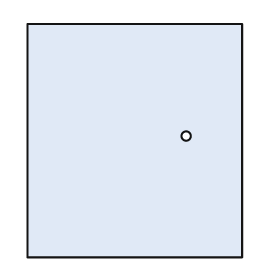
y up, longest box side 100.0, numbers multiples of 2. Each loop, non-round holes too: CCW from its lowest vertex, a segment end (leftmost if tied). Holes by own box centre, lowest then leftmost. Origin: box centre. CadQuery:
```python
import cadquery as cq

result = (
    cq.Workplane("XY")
    .moveTo(-46.0, -50.0)
    .lineTo(46.0, -50.0)
    .lineTo(46.0, 50.0)
    .lineTo(-46.0, 50.0)
    .close()
    .moveTo(22.0, 2.0)
    .circle(2.0)
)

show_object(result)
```